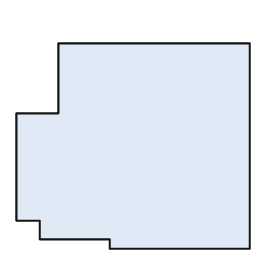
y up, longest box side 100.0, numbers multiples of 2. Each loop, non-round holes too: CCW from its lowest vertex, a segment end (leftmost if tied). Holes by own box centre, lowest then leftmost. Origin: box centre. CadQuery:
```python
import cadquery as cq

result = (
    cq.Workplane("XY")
    .moveTo(-10.0, -44.0)
    .lineTo(50.0, -44.0)
    .lineTo(50.0, 44.0)
    .lineTo(-32.0, 44.0)
    .lineTo(-32.0, 14.0)
    .lineTo(-50.0, 14.0)
    .lineTo(-50.0, -32.0)
    .lineTo(-40.0, -32.0)
    .lineTo(-40.0, -40.0)
    .lineTo(-10.0, -40.0)
    .close()
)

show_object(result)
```